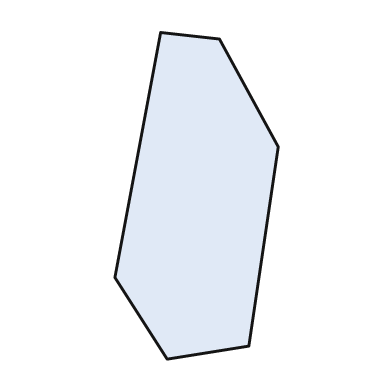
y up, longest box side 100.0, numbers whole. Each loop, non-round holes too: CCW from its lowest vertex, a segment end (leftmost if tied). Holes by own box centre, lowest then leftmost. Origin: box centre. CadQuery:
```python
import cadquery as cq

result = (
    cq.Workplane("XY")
    .moveTo(-9.0, -50.0)
    .lineTo(16.0, -46.0)
    .lineTo(25.0, 15.0)
    .lineTo(7.0, 48.0)
    .lineTo(-11.0, 50.0)
    .lineTo(-25.0, -25.0)
    .close()
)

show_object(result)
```